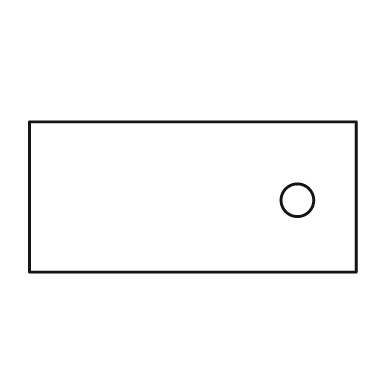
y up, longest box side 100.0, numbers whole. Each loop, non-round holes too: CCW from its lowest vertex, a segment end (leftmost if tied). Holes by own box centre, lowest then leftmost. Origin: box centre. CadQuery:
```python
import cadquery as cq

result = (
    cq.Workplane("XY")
    .moveTo(-50.0, -23.0)
    .lineTo(50.0, -23.0)
    .lineTo(50.0, 23.0)
    .lineTo(-50.0, 23.0)
    .close()
    .moveTo(32.0, -1.0)
    .circle(5.0)
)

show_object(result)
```